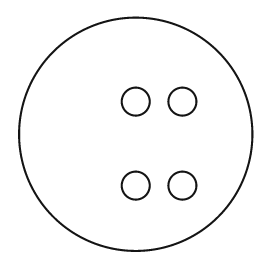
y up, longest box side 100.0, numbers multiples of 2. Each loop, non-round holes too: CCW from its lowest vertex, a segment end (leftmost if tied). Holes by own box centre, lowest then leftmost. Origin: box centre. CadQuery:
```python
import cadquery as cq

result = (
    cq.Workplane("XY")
    .moveTo(0.0, 0.0)
    .circle(50.0)
    .moveTo(0.0, -22.0)
    .circle(6.0)
    .moveTo(20.0, -22.0)
    .circle(6.0)
    .moveTo(0.0, 14.0)
    .circle(6.0)
    .moveTo(20.0, 14.0)
    .circle(6.0)
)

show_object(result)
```